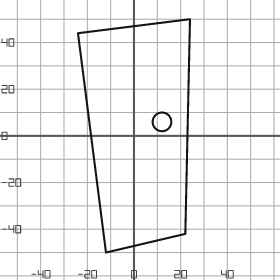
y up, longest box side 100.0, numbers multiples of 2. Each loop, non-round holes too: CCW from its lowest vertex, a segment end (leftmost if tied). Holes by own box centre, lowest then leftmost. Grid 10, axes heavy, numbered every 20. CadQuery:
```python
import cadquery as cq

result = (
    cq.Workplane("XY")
    .moveTo(-12.0, -50.0)
    .lineTo(22.0, -42.0)
    .lineTo(24.0, 50.0)
    .lineTo(-24.0, 44.0)
    .close()
    .moveTo(12.0, 6.0)
    .circle(4.0)
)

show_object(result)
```